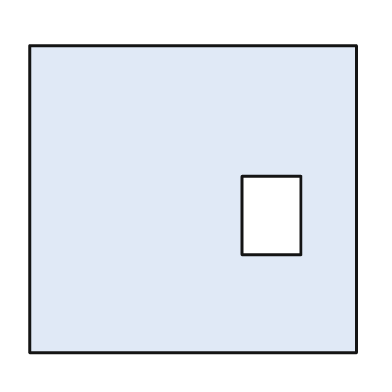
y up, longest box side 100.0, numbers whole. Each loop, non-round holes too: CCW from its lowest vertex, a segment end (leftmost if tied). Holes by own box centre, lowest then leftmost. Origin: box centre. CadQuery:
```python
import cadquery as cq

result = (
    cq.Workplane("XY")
    .moveTo(-50.0, -47.0)
    .lineTo(50.0, -47.0)
    .lineTo(50.0, 47.0)
    .lineTo(-50.0, 47.0)
    .close()
    .moveTo(15.0, -17.0)
    .lineTo(33.0, -17.0)
    .lineTo(33.0, 7.0)
    .lineTo(15.0, 7.0)
    .close()
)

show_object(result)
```